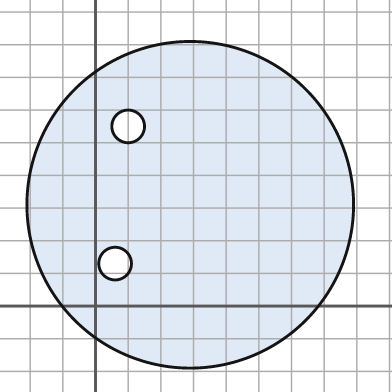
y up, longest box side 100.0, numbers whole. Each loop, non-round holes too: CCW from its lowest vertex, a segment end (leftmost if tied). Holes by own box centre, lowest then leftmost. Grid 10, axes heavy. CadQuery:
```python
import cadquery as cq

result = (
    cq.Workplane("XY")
    .moveTo(29.0, 31.0)
    .circle(50.0)
    .moveTo(6.0, 13.0)
    .circle(5.0)
    .moveTo(10.0, 55.0)
    .circle(5.0)
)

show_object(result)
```